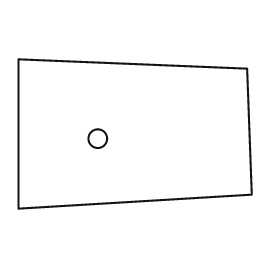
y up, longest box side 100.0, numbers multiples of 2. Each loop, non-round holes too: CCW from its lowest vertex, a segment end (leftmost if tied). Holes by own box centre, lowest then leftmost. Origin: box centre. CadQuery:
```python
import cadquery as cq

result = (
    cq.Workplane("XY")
    .moveTo(-50.0, -32.0)
    .lineTo(50.0, -26.0)
    .lineTo(48.0, 28.0)
    .lineTo(-50.0, 32.0)
    .close()
    .moveTo(-16.0, -2.0)
    .circle(4.0)
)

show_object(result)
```